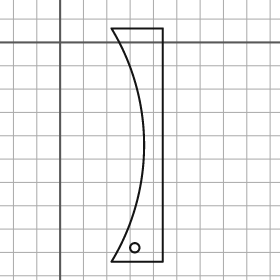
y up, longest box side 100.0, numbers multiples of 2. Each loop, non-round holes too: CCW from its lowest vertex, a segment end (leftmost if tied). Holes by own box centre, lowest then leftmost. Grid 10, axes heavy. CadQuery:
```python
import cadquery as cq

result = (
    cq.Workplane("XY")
    .moveTo(22.0, -94.0)
    .lineTo(44.0, -94.0)
    .lineTo(44.0, 6.0)
    .lineTo(22.0, 6.0)
    .threePointArc((36.0, -44.0), (22.0, -94.0))
    .close()
    .moveTo(32.0, -88.0)
    .circle(2.0)
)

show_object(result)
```